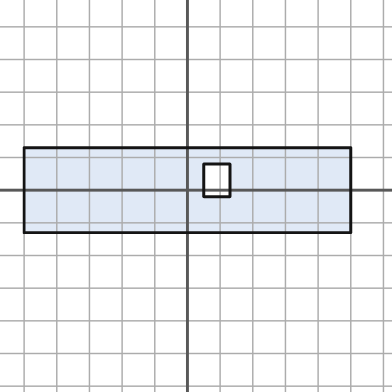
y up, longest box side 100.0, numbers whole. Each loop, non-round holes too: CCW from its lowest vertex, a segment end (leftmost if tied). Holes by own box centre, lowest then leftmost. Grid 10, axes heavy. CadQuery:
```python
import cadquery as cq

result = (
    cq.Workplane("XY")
    .moveTo(-50.0, -13.0)
    .lineTo(50.0, -13.0)
    .lineTo(50.0, 13.0)
    .lineTo(-50.0, 13.0)
    .close()
    .moveTo(5.0, -2.0)
    .lineTo(13.0, -2.0)
    .lineTo(13.0, 8.0)
    .lineTo(5.0, 8.0)
    .close()
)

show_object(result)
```